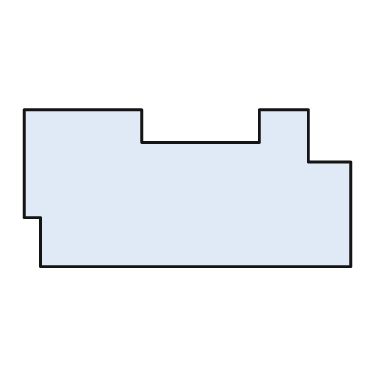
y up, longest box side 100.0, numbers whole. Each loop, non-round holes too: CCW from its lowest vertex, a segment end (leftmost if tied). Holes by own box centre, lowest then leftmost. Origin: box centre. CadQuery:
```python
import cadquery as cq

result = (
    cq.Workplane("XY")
    .moveTo(-45.0, -24.0)
    .lineTo(50.0, -24.0)
    .lineTo(50.0, 8.0)
    .lineTo(37.0, 8.0)
    .lineTo(37.0, 24.0)
    .lineTo(22.0, 24.0)
    .lineTo(22.0, 14.0)
    .lineTo(-14.0, 14.0)
    .lineTo(-14.0, 24.0)
    .lineTo(-50.0, 24.0)
    .lineTo(-50.0, -9.0)
    .lineTo(-45.0, -9.0)
    .close()
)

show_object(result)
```